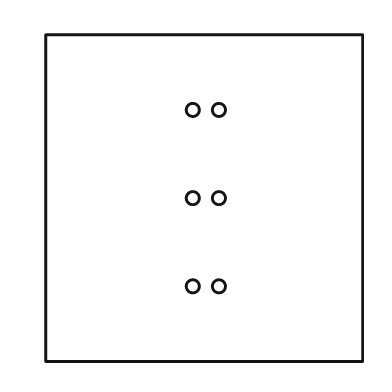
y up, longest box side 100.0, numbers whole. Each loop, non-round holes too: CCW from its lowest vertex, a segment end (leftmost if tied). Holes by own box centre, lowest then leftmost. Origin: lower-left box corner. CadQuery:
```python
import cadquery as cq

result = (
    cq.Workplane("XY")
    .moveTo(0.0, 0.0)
    .lineTo(97.0, 0.0)
    .lineTo(97.0, 100.0)
    .lineTo(0.0, 100.0)
    .close()
    .moveTo(45.0, 23.0)
    .circle(2.0)
    .moveTo(53.0, 23.0)
    .circle(2.0)
    .moveTo(45.0, 50.0)
    .circle(2.0)
    .moveTo(53.0, 50.0)
    .circle(2.0)
    .moveTo(45.0, 77.0)
    .circle(2.0)
    .moveTo(53.0, 77.0)
    .circle(2.0)
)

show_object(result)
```